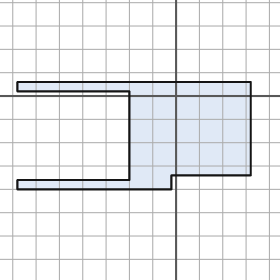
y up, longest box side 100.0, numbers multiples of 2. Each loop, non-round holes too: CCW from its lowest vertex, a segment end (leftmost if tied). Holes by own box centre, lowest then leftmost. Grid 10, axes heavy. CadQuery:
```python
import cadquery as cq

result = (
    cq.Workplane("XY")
    .moveTo(-68.0, -40.0)
    .lineTo(-2.0, -40.0)
    .lineTo(-2.0, -34.0)
    .lineTo(32.0, -34.0)
    .lineTo(32.0, 6.0)
    .lineTo(-68.0, 6.0)
    .lineTo(-68.0, 2.0)
    .lineTo(-20.0, 2.0)
    .lineTo(-20.0, -36.0)
    .lineTo(-68.0, -36.0)
    .close()
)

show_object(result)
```